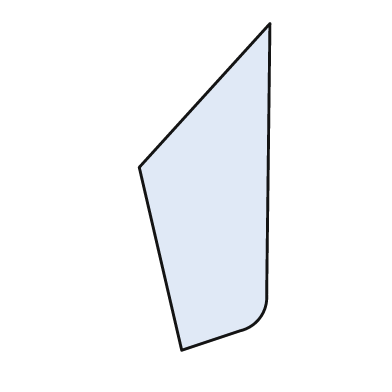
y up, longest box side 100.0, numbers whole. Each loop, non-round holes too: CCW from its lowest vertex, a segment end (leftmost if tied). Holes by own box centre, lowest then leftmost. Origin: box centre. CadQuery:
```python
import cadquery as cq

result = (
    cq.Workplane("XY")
    .moveTo(-7.0, -50.0)
    .lineTo(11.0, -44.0)
    .threePointArc((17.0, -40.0), (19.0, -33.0))
    .lineTo(20.0, 50.0)
    .lineTo(-20.0, 6.0)
    .close()
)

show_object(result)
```